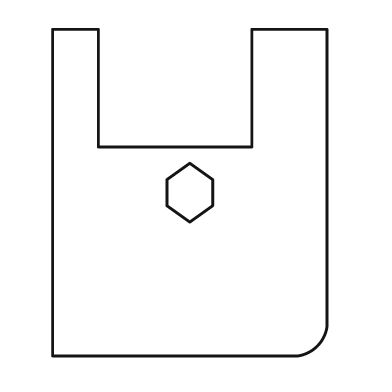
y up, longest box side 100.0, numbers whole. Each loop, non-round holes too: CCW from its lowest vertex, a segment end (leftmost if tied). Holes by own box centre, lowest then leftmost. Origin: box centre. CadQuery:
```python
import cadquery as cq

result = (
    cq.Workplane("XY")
    .moveTo(-42.0, -50.0)
    .lineTo(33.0, -50.0)
    .threePointArc((39.0, -47.0), (42.0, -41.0))
    .lineTo(42.0, 50.0)
    .lineTo(19.0, 50.0)
    .lineTo(19.0, 14.0)
    .lineTo(-28.0, 14.0)
    .lineTo(-28.0, 50.0)
    .lineTo(-42.0, 50.0)
    .close()
    .moveTo(0.0, -9.0)
    .lineTo(7.0, -4.0)
    .lineTo(7.0, 4.0)
    .lineTo(0.0, 9.0)
    .lineTo(-7.0, 4.0)
    .lineTo(-7.0, -4.0)
    .close()
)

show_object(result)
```